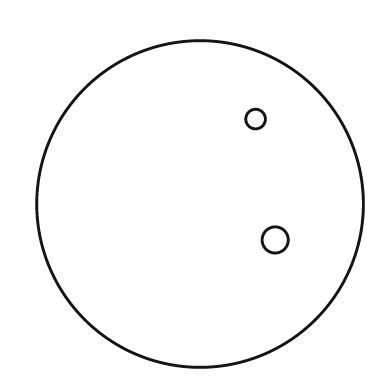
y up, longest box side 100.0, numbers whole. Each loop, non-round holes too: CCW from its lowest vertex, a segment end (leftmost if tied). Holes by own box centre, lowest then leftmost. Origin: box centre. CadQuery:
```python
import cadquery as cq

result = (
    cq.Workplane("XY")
    .moveTo(0.0, 0.0)
    .circle(50.0)
    .moveTo(23.0, -11.0)
    .circle(4.0)
    .moveTo(17.0, 26.0)
    .circle(3.0)
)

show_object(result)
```